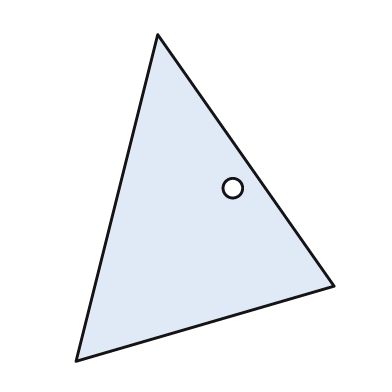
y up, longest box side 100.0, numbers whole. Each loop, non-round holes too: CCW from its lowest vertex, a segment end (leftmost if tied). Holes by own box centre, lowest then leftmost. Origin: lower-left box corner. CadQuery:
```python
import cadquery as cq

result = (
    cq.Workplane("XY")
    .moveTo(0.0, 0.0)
    .lineTo(79.0, 23.0)
    .lineTo(25.0, 100.0)
    .close()
    .moveTo(48.0, 53.0)
    .circle(3.0)
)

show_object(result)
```